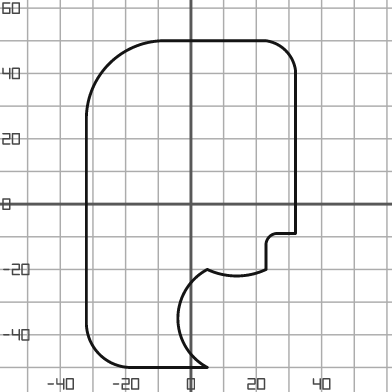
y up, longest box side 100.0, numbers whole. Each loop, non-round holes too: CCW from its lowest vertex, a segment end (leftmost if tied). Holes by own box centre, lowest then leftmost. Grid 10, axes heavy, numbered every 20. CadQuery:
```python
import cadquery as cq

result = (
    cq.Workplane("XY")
    .moveTo(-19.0, -50.0)
    .lineTo(5.0, -50.0)
    .threePointArc((-4.0, -35.0), (5.0, -20.0))
    .threePointArc((14.0, -22.0), (23.0, -20.0))
    .lineTo(23.0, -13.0)
    .threePointArc((24.0, -10.0), (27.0, -9.0))
    .lineTo(32.0, -9.0)
    .lineTo(32.0, 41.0)
    .threePointArc((29.0, 47.0), (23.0, 50.0))
    .lineTo(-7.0, 50.0)
    .threePointArc((-25.0, 43.0), (-32.0, 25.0))
    .lineTo(-32.0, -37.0)
    .threePointArc((-28.0, -46.0), (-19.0, -50.0))
    .close()
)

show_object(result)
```